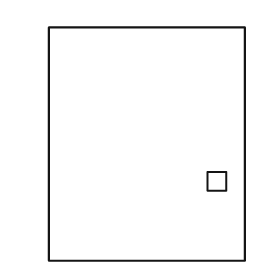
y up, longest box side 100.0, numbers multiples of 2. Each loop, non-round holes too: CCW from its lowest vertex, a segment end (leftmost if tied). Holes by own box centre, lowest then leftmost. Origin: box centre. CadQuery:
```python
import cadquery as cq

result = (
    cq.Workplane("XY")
    .moveTo(-42.0, -50.0)
    .lineTo(42.0, -50.0)
    .lineTo(42.0, 50.0)
    .lineTo(-42.0, 50.0)
    .close()
    .moveTo(26.0, -20.0)
    .lineTo(34.0, -20.0)
    .lineTo(34.0, -12.0)
    .lineTo(26.0, -12.0)
    .close()
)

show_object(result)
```